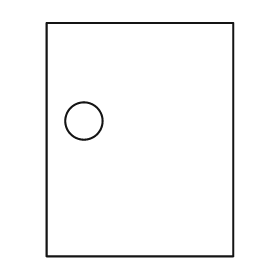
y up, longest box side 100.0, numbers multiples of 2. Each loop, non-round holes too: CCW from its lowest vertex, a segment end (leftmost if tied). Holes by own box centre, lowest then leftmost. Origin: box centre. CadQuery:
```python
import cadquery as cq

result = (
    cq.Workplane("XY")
    .moveTo(-40.0, -50.0)
    .lineTo(40.0, -50.0)
    .lineTo(40.0, 50.0)
    .lineTo(-40.0, 50.0)
    .close()
    .moveTo(-24.0, 8.0)
    .circle(8.0)
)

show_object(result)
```